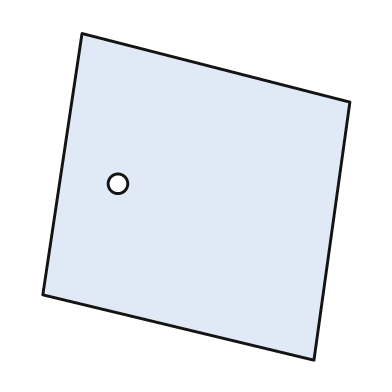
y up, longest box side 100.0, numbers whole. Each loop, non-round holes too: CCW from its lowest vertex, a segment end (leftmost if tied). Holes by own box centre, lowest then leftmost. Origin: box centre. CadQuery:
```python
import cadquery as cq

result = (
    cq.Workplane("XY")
    .moveTo(36.0, -50.0)
    .lineTo(47.0, 29.0)
    .lineTo(-35.0, 50.0)
    .lineTo(-47.0, -30.0)
    .close()
    .moveTo(-24.0, 4.0)
    .circle(3.0)
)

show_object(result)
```